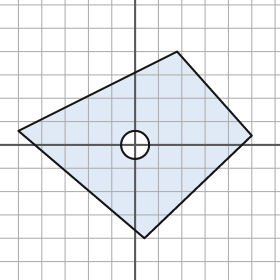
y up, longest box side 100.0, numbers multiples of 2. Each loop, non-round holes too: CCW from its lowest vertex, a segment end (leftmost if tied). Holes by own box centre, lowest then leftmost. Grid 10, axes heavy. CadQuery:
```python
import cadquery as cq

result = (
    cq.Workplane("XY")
    .moveTo(4.0, -40.0)
    .lineTo(50.0, 4.0)
    .lineTo(18.0, 40.0)
    .lineTo(-50.0, 6.0)
    .close()
    .moveTo(0.0, 0.0)
    .circle(6.0)
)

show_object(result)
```